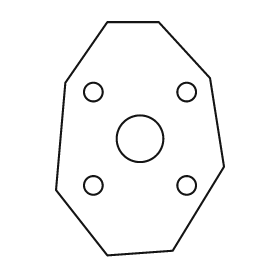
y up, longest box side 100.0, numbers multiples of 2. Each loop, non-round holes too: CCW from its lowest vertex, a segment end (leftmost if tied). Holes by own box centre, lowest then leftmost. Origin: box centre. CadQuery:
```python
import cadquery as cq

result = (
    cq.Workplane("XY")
    .moveTo(-14.0, -50.0)
    .lineTo(14.0, -48.0)
    .lineTo(36.0, -12.0)
    .lineTo(30.0, 26.0)
    .lineTo(8.0, 50.0)
    .lineTo(-14.0, 50.0)
    .lineTo(-32.0, 24.0)
    .lineTo(-36.0, -22.0)
    .close()
    .moveTo(-20.0, -20.0)
    .circle(4.0)
    .moveTo(20.0, -20.0)
    .circle(4.0)
    .moveTo(0.0, 0.0)
    .circle(10.0)
    .moveTo(-20.0, 20.0)
    .circle(4.0)
    .moveTo(20.0, 20.0)
    .circle(4.0)
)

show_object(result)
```